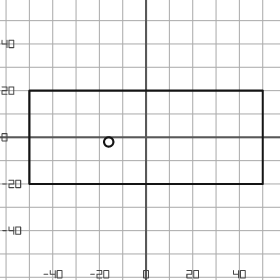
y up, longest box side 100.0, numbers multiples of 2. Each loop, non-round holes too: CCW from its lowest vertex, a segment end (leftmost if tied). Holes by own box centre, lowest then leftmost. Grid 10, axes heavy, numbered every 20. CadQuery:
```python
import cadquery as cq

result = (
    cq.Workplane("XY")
    .moveTo(-50.0, -20.0)
    .lineTo(50.0, -20.0)
    .lineTo(50.0, 20.0)
    .lineTo(-50.0, 20.0)
    .close()
    .moveTo(-16.0, -2.0)
    .circle(2.0)
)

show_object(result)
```